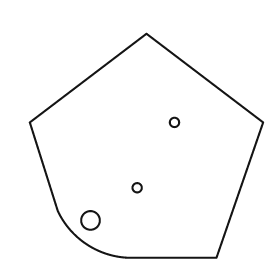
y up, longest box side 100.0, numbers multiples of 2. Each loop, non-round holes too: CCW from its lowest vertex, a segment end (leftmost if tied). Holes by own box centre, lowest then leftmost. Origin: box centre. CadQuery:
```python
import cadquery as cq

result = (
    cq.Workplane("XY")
    .moveTo(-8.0, -48.0)
    .lineTo(30.0, -48.0)
    .lineTo(50.0, 10.0)
    .lineTo(0.0, 48.0)
    .lineTo(-50.0, 10.0)
    .lineTo(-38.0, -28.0)
    .threePointArc((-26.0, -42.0), (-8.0, -48.0))
    .close()
    .moveTo(-24.0, -32.0)
    .circle(4.0)
    .moveTo(-4.0, -18.0)
    .circle(2.0)
    .moveTo(12.0, 10.0)
    .circle(2.0)
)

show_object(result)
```